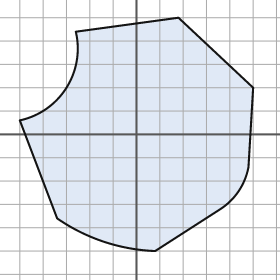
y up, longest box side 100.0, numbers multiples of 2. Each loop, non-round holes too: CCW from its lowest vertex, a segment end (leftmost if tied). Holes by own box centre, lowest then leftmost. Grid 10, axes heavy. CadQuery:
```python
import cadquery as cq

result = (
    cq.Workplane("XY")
    .moveTo(8.0, -50.0)
    .lineTo(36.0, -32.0)
    .threePointArc((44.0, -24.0), (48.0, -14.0))
    .lineTo(50.0, 20.0)
    .lineTo(18.0, 50.0)
    .lineTo(-26.0, 44.0)
    .threePointArc((-30.0, 20.0), (-50.0, 6.0))
    .lineTo(-34.0, -36.0)
    .threePointArc((-14.0, -46.0), (8.0, -50.0))
    .close()
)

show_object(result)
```